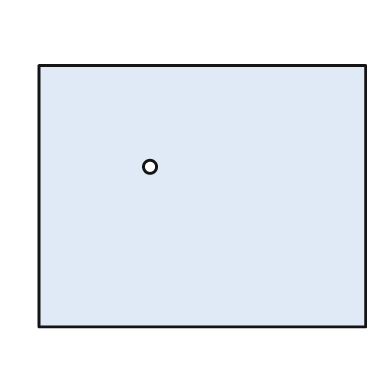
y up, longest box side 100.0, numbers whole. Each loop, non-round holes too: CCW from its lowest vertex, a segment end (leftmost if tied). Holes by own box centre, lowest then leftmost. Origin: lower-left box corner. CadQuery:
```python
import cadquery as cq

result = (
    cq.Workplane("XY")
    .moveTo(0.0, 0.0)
    .lineTo(100.0, 0.0)
    .lineTo(100.0, 80.0)
    .lineTo(0.0, 80.0)
    .close()
    .moveTo(34.0, 49.0)
    .circle(2.0)
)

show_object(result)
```